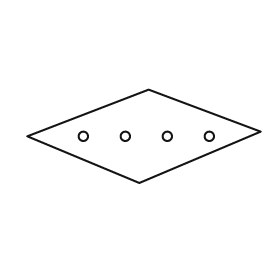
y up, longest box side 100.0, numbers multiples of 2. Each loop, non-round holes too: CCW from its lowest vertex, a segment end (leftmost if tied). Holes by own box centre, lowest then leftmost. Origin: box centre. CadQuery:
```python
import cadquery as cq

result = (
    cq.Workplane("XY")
    .moveTo(-2.0, -20.0)
    .lineTo(50.0, 2.0)
    .lineTo(2.0, 20.0)
    .lineTo(-50.0, 0.0)
    .close()
    .moveTo(-26.0, 0.0)
    .circle(2.0)
    .moveTo(-8.0, 0.0)
    .circle(2.0)
    .moveTo(10.0, 0.0)
    .circle(2.0)
    .moveTo(28.0, 0.0)
    .circle(2.0)
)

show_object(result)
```